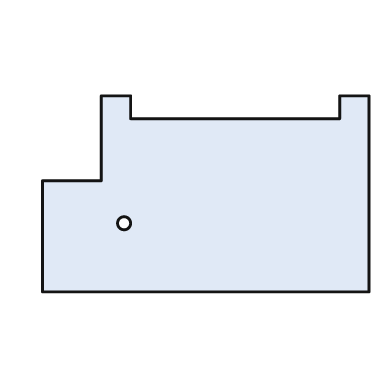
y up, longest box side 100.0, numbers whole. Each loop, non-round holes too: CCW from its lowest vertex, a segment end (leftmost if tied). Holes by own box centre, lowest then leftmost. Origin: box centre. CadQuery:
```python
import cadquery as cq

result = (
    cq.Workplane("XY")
    .moveTo(-50.0, -30.0)
    .lineTo(50.0, -30.0)
    .lineTo(50.0, 30.0)
    .lineTo(41.0, 30.0)
    .lineTo(41.0, 23.0)
    .lineTo(-23.0, 23.0)
    .lineTo(-23.0, 30.0)
    .lineTo(-32.0, 30.0)
    .lineTo(-32.0, 4.0)
    .lineTo(-50.0, 4.0)
    .close()
    .moveTo(-25.0, -9.0)
    .circle(2.0)
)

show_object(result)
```